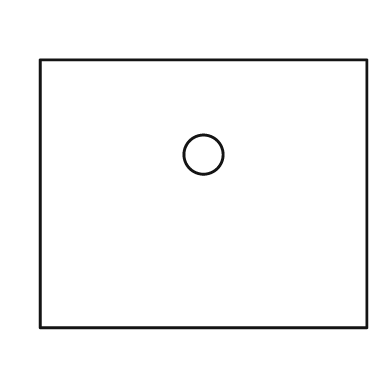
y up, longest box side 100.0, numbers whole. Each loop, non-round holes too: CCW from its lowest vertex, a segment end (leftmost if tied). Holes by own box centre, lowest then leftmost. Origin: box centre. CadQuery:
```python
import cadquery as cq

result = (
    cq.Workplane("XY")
    .moveTo(-50.0, -41.0)
    .lineTo(50.0, -41.0)
    .lineTo(50.0, 41.0)
    .lineTo(-50.0, 41.0)
    .close()
    .moveTo(0.0, 12.0)
    .circle(6.0)
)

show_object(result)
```